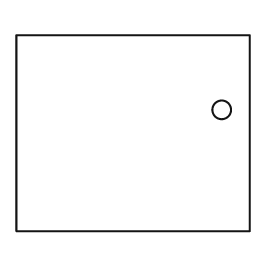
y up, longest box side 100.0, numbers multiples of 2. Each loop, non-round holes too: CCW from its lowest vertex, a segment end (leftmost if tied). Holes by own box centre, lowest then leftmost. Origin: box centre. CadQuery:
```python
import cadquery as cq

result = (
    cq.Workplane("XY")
    .moveTo(-50.0, -42.0)
    .lineTo(50.0, -42.0)
    .lineTo(50.0, 42.0)
    .lineTo(-50.0, 42.0)
    .close()
    .moveTo(38.0, 10.0)
    .circle(4.0)
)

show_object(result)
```